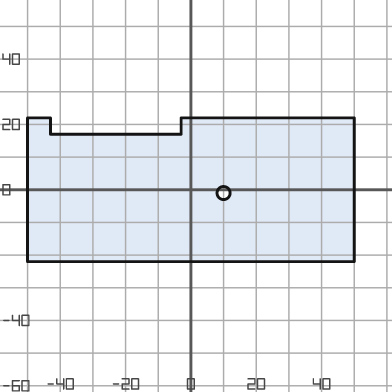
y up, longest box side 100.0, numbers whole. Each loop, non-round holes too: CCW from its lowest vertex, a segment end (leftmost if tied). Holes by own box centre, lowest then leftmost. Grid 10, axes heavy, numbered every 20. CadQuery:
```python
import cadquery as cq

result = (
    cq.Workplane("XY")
    .moveTo(-50.0, -22.0)
    .lineTo(50.0, -22.0)
    .lineTo(50.0, 22.0)
    .lineTo(-3.0, 22.0)
    .lineTo(-3.0, 17.0)
    .lineTo(-43.0, 17.0)
    .lineTo(-43.0, 22.0)
    .lineTo(-50.0, 22.0)
    .close()
    .moveTo(10.0, -1.0)
    .circle(2.0)
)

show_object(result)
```